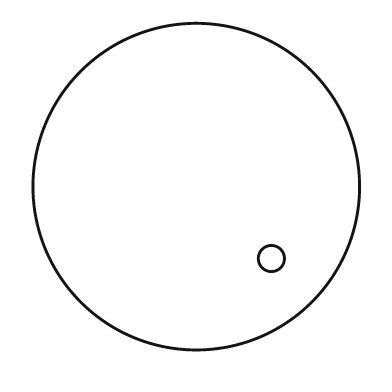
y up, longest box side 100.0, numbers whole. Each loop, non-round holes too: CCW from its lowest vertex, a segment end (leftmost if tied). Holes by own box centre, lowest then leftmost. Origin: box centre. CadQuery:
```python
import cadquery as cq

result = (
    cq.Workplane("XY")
    .moveTo(0.0, 0.0)
    .circle(50.0)
    .moveTo(23.0, -22.0)
    .circle(4.0)
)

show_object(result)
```